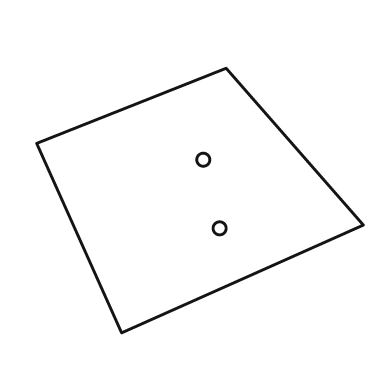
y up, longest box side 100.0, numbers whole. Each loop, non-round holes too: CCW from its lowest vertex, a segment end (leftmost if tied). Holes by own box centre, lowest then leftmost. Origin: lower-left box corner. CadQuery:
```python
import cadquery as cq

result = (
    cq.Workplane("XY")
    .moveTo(26.0, 0.0)
    .lineTo(100.0, 33.0)
    .lineTo(58.0, 81.0)
    .lineTo(0.0, 58.0)
    .close()
    .moveTo(56.0, 32.0)
    .circle(2.0)
    .moveTo(51.0, 53.0)
    .circle(2.0)
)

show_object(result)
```